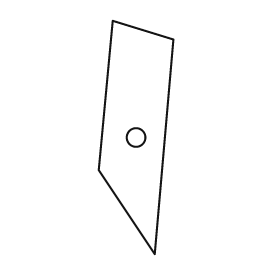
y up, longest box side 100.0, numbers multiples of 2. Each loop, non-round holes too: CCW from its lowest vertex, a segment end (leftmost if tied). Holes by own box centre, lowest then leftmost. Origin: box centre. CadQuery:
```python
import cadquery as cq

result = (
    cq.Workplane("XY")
    .moveTo(8.0, -50.0)
    .lineTo(16.0, 42.0)
    .lineTo(-10.0, 50.0)
    .lineTo(-16.0, -14.0)
    .close()
    .moveTo(0.0, 0.0)
    .circle(4.0)
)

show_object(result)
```